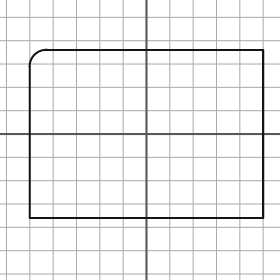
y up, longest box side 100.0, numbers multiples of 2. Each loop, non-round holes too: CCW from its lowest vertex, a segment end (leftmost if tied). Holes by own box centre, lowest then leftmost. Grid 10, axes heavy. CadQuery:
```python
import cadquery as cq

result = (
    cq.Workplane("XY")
    .moveTo(-50.0, -36.0)
    .lineTo(50.0, -36.0)
    .lineTo(50.0, 36.0)
    .lineTo(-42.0, 36.0)
    .threePointArc((-48.0, 34.0), (-50.0, 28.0))
    .close()
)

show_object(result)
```